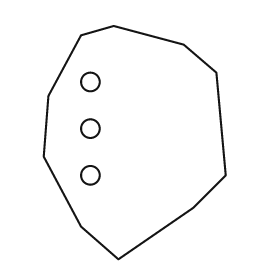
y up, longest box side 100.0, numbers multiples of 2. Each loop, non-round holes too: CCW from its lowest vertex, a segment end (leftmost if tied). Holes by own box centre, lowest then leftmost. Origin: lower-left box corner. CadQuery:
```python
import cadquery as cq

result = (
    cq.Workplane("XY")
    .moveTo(32.0, 0.0)
    .lineTo(64.0, 22.0)
    .lineTo(78.0, 36.0)
    .lineTo(74.0, 80.0)
    .lineTo(60.0, 92.0)
    .lineTo(30.0, 100.0)
    .lineTo(16.0, 96.0)
    .lineTo(2.0, 70.0)
    .lineTo(0.0, 44.0)
    .lineTo(16.0, 14.0)
    .close()
    .moveTo(20.0, 36.0)
    .circle(4.0)
    .moveTo(20.0, 56.0)
    .circle(4.0)
    .moveTo(20.0, 76.0)
    .circle(4.0)
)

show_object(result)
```